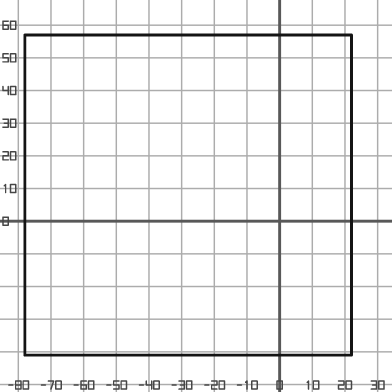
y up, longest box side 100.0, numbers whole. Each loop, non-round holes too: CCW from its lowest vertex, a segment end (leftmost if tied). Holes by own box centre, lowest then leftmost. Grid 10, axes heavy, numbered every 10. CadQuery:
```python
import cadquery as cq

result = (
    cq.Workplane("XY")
    .moveTo(-78.0, -41.0)
    .lineTo(22.0, -41.0)
    .lineTo(22.0, 57.0)
    .lineTo(-78.0, 57.0)
    .close()
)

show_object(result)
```